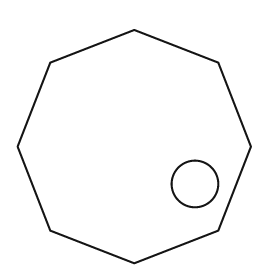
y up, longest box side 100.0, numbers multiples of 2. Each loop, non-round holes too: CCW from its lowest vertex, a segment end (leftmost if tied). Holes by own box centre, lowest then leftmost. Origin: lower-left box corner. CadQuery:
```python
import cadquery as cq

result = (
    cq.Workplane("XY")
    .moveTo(50.0, 0.0)
    .lineTo(86.0, 14.0)
    .lineTo(100.0, 50.0)
    .lineTo(86.0, 86.0)
    .lineTo(50.0, 100.0)
    .lineTo(14.0, 86.0)
    .lineTo(0.0, 50.0)
    .lineTo(14.0, 14.0)
    .close()
    .moveTo(76.0, 34.0)
    .circle(10.0)
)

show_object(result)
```